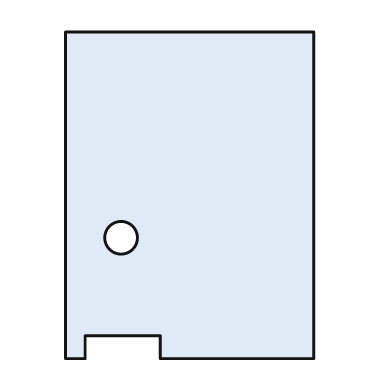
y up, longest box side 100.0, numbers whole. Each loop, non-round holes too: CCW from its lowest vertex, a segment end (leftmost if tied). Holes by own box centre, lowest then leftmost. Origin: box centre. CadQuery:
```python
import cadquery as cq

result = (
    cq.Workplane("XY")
    .moveTo(-38.0, -50.0)
    .lineTo(-32.0, -50.0)
    .lineTo(-32.0, -43.0)
    .lineTo(-9.0, -43.0)
    .lineTo(-9.0, -50.0)
    .lineTo(38.0, -50.0)
    .lineTo(38.0, 50.0)
    .lineTo(-38.0, 50.0)
    .close()
    .moveTo(-21.0, -13.0)
    .circle(5.0)
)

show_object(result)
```